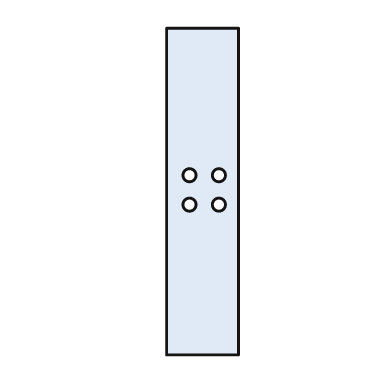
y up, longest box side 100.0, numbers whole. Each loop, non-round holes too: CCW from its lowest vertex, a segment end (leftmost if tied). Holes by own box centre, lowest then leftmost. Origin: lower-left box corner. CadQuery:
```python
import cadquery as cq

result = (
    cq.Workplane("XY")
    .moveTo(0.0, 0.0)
    .lineTo(22.0, 0.0)
    .lineTo(22.0, 100.0)
    .lineTo(0.0, 100.0)
    .close()
    .moveTo(7.0, 46.0)
    .circle(2.0)
    .moveTo(16.0, 46.0)
    .circle(2.0)
    .moveTo(7.0, 55.0)
    .circle(2.0)
    .moveTo(16.0, 55.0)
    .circle(2.0)
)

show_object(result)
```